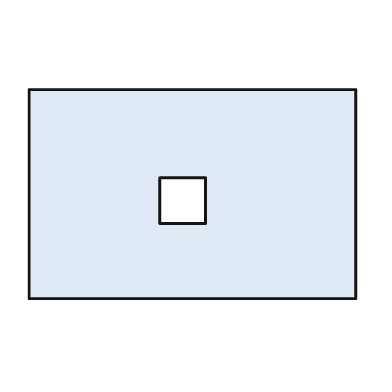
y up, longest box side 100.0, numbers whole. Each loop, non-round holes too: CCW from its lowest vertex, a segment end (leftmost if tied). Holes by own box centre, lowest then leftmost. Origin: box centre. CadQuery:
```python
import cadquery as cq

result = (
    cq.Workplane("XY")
    .moveTo(-50.0, -32.0)
    .lineTo(50.0, -32.0)
    .lineTo(50.0, 32.0)
    .lineTo(-50.0, 32.0)
    .close()
    .moveTo(-10.0, -9.0)
    .lineTo(4.0, -9.0)
    .lineTo(4.0, 5.0)
    .lineTo(-10.0, 5.0)
    .close()
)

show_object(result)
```